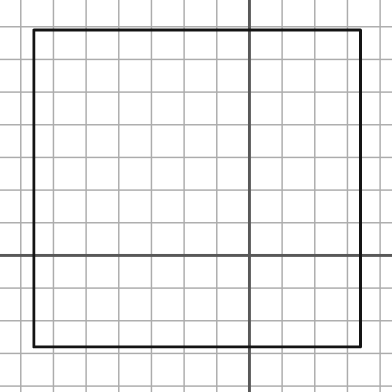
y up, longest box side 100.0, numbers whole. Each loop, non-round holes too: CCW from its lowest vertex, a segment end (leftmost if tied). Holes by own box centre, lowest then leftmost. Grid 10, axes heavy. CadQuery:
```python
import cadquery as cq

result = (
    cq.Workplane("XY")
    .moveTo(-66.0, -28.0)
    .lineTo(34.0, -28.0)
    .lineTo(34.0, 69.0)
    .lineTo(-66.0, 69.0)
    .close()
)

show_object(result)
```